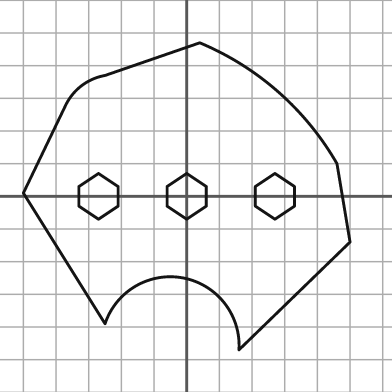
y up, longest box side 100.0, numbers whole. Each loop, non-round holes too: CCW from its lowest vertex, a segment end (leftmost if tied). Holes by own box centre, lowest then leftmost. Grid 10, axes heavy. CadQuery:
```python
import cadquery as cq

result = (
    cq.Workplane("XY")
    .moveTo(16.0, -47.0)
    .lineTo(50.0, -14.0)
    .lineTo(46.0, 10.0)
    .threePointArc((28.0, 32.0), (4.0, 47.0))
    .lineTo(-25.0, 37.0)
    .threePointArc((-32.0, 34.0), (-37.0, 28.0))
    .lineTo(-50.0, 1.0)
    .lineTo(-25.0, -39.0)
    .threePointArc((-1.0, -25.0), (16.0, -47.0))
    .close()
    .moveTo(-27.0, -7.0)
    .lineTo(-21.0, -3.0)
    .lineTo(-21.0, 3.0)
    .lineTo(-27.0, 7.0)
    .lineTo(-33.0, 3.0)
    .lineTo(-33.0, -3.0)
    .close()
    .moveTo(0.0, -7.0)
    .lineTo(6.0, -3.0)
    .lineTo(6.0, 3.0)
    .lineTo(0.0, 7.0)
    .lineTo(-6.0, 3.0)
    .lineTo(-6.0, -3.0)
    .close()
    .moveTo(27.0, -7.0)
    .lineTo(33.0, -3.0)
    .lineTo(33.0, 3.0)
    .lineTo(27.0, 7.0)
    .lineTo(21.0, 3.0)
    .lineTo(21.0, -3.0)
    .close()
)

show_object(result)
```